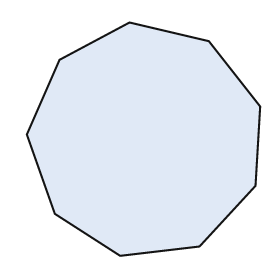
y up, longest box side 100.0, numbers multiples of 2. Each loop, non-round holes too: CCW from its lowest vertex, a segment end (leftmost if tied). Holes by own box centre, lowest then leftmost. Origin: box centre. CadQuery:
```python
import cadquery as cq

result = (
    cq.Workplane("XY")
    .moveTo(-10.0, -50.0)
    .lineTo(24.0, -46.0)
    .lineTo(48.0, -20.0)
    .lineTo(50.0, 14.0)
    .lineTo(28.0, 42.0)
    .lineTo(-6.0, 50.0)
    .lineTo(-36.0, 34.0)
    .lineTo(-50.0, 2.0)
    .lineTo(-38.0, -32.0)
    .close()
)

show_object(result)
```